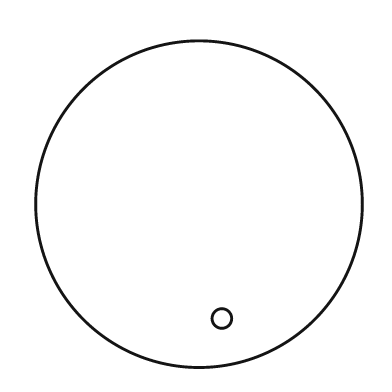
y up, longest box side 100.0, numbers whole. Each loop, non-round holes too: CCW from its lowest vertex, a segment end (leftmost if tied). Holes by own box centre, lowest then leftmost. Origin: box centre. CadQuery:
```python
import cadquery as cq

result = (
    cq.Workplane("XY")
    .moveTo(0.0, 0.0)
    .circle(50.0)
    .moveTo(7.0, -35.0)
    .circle(3.0)
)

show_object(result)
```